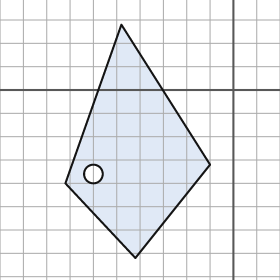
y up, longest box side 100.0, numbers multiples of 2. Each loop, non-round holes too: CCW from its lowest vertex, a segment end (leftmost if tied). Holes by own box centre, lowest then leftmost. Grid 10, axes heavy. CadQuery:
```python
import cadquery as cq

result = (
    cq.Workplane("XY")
    .moveTo(-42.0, -72.0)
    .lineTo(-10.0, -32.0)
    .lineTo(-48.0, 28.0)
    .lineTo(-72.0, -40.0)
    .close()
    .moveTo(-60.0, -36.0)
    .circle(4.0)
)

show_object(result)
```